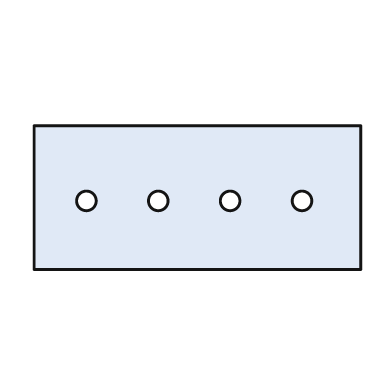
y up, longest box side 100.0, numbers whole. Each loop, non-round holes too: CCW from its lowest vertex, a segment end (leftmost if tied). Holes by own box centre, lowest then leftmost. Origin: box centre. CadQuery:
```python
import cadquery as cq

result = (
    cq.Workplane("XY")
    .moveTo(-50.0, -22.0)
    .lineTo(50.0, -22.0)
    .lineTo(50.0, 22.0)
    .lineTo(-50.0, 22.0)
    .close()
    .moveTo(-34.0, -1.0)
    .circle(3.0)
    .moveTo(-12.0, -1.0)
    .circle(3.0)
    .moveTo(10.0, -1.0)
    .circle(3.0)
    .moveTo(32.0, -1.0)
    .circle(3.0)
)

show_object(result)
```